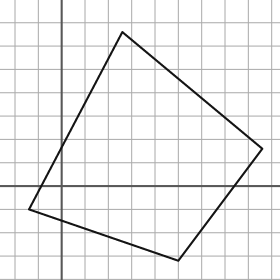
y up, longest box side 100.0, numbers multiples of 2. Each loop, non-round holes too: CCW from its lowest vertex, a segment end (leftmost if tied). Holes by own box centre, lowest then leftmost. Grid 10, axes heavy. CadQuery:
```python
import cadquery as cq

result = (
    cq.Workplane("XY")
    .moveTo(50.0, -32.0)
    .lineTo(86.0, 16.0)
    .lineTo(26.0, 66.0)
    .lineTo(-14.0, -10.0)
    .close()
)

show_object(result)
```